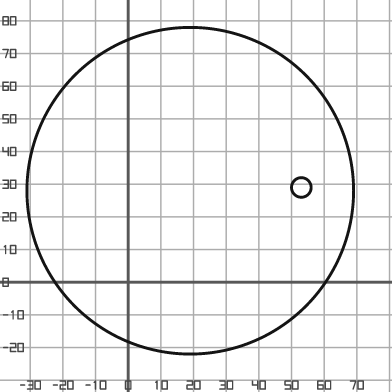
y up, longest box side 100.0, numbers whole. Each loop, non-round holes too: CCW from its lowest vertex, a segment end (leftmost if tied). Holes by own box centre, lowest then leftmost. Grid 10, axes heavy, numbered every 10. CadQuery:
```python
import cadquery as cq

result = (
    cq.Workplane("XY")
    .moveTo(19.0, 28.0)
    .circle(50.0)
    .moveTo(53.0, 29.0)
    .circle(3.0)
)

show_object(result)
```